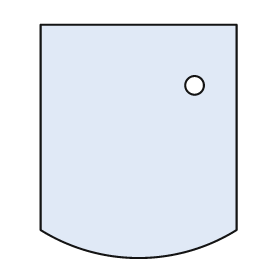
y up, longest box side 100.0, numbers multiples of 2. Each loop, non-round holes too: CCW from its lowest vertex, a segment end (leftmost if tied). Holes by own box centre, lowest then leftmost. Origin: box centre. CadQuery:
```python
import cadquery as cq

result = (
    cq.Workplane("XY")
    .moveTo(-42.0, -38.0)
    .threePointArc((0.0, -50.0), (42.0, -38.0))
    .lineTo(42.0, 50.0)
    .lineTo(-42.0, 50.0)
    .close()
    .moveTo(24.0, 24.0)
    .circle(4.0)
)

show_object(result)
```